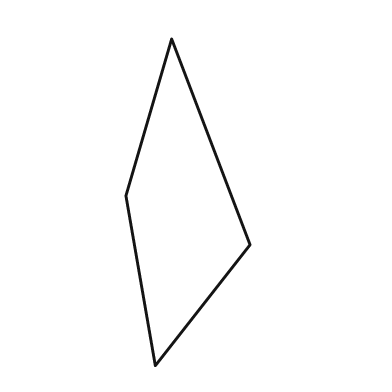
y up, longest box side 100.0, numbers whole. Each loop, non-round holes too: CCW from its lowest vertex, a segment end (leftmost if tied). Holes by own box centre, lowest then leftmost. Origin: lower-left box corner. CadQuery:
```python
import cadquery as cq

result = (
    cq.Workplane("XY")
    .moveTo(9.0, 0.0)
    .lineTo(38.0, 37.0)
    .lineTo(14.0, 100.0)
    .lineTo(0.0, 52.0)
    .close()
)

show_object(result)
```